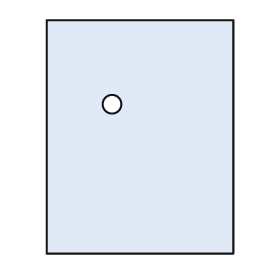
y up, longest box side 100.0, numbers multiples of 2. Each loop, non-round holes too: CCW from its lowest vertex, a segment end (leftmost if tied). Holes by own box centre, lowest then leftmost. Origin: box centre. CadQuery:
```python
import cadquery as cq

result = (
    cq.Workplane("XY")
    .moveTo(-40.0, -50.0)
    .lineTo(40.0, -50.0)
    .lineTo(40.0, 50.0)
    .lineTo(-40.0, 50.0)
    .close()
    .moveTo(-12.0, 14.0)
    .circle(4.0)
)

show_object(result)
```